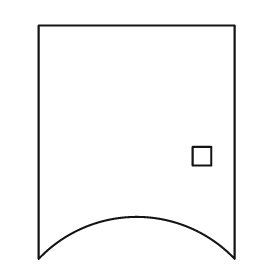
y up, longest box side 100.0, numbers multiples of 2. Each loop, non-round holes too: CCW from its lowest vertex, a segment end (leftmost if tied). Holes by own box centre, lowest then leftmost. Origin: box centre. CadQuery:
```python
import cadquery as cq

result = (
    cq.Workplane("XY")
    .moveTo(-42.0, -50.0)
    .threePointArc((0.0, -32.0), (42.0, -50.0))
    .lineTo(42.0, 50.0)
    .lineTo(-42.0, 50.0)
    .close()
    .moveTo(24.0, -10.0)
    .lineTo(32.0, -10.0)
    .lineTo(32.0, -2.0)
    .lineTo(24.0, -2.0)
    .close()
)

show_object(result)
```